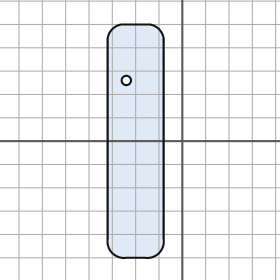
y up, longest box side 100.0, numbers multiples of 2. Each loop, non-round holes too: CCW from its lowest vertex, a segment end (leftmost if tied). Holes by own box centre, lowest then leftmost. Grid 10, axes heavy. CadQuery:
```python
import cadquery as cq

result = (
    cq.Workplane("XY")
    .moveTo(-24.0, -50.0)
    .lineTo(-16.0, -50.0)
    .threePointArc((-10.0, -48.0), (-8.0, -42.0))
    .lineTo(-8.0, 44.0)
    .threePointArc((-10.0, 48.0), (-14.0, 50.0))
    .lineTo(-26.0, 50.0)
    .threePointArc((-30.0, 48.0), (-32.0, 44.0))
    .lineTo(-32.0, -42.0)
    .threePointArc((-30.0, -48.0), (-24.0, -50.0))
    .close()
    .moveTo(-24.0, 26.0)
    .circle(2.0)
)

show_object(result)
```